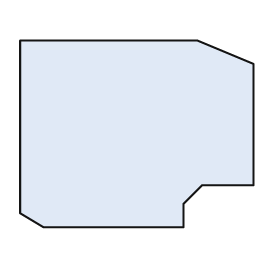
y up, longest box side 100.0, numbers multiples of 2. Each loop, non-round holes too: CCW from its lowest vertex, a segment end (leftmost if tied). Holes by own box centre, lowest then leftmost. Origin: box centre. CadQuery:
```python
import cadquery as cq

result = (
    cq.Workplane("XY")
    .moveTo(-40.0, -40.0)
    .lineTo(20.0, -40.0)
    .lineTo(20.0, -30.0)
    .lineTo(28.0, -22.0)
    .lineTo(50.0, -22.0)
    .lineTo(50.0, 30.0)
    .lineTo(26.0, 40.0)
    .lineTo(-50.0, 40.0)
    .lineTo(-50.0, -34.0)
    .close()
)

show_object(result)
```